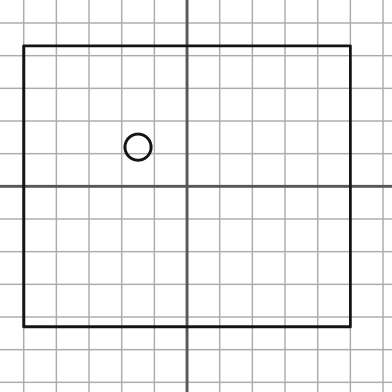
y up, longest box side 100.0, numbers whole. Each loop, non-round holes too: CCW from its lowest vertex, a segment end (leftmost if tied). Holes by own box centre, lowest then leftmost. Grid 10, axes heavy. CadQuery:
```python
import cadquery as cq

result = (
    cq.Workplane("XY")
    .moveTo(-50.0, -43.0)
    .lineTo(50.0, -43.0)
    .lineTo(50.0, 43.0)
    .lineTo(-50.0, 43.0)
    .close()
    .moveTo(-15.0, 12.0)
    .circle(4.0)
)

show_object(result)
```